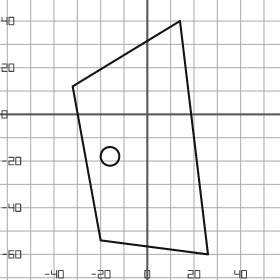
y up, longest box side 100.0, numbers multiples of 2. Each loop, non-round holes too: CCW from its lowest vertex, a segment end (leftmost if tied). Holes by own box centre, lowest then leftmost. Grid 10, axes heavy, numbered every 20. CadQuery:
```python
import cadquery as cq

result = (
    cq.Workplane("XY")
    .moveTo(26.0, -60.0)
    .lineTo(14.0, 40.0)
    .lineTo(-32.0, 12.0)
    .lineTo(-20.0, -54.0)
    .close()
    .moveTo(-16.0, -18.0)
    .circle(4.0)
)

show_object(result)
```